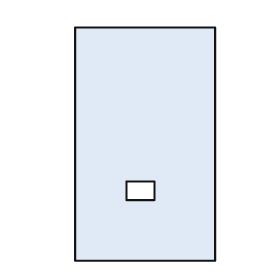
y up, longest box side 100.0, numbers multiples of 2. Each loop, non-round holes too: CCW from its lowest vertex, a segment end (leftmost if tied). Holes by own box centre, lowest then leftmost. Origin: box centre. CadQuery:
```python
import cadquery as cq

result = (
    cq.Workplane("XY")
    .moveTo(-30.0, -50.0)
    .lineTo(30.0, -50.0)
    .lineTo(30.0, 50.0)
    .lineTo(-30.0, 50.0)
    .close()
    .moveTo(-8.0, -24.0)
    .lineTo(4.0, -24.0)
    .lineTo(4.0, -16.0)
    .lineTo(-8.0, -16.0)
    .close()
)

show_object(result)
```